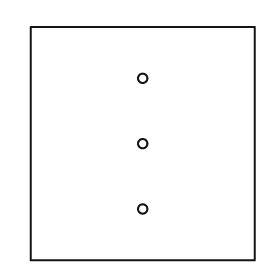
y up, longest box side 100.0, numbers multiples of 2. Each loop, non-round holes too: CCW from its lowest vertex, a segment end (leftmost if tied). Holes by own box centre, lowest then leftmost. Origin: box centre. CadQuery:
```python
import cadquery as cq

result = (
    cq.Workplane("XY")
    .moveTo(-48.0, -50.0)
    .lineTo(48.0, -50.0)
    .lineTo(48.0, 50.0)
    .lineTo(-48.0, 50.0)
    .close()
    .moveTo(0.0, -28.0)
    .circle(2.0)
    .moveTo(0.0, 0.0)
    .circle(2.0)
    .moveTo(0.0, 28.0)
    .circle(2.0)
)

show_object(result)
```